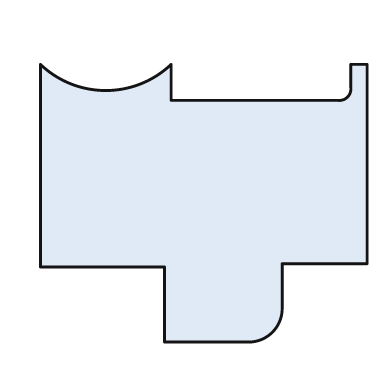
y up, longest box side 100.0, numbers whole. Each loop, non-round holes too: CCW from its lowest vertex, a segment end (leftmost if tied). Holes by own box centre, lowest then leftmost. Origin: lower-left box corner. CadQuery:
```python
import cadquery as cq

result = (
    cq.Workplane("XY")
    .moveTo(38.0, 0.0)
    .lineTo(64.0, 0.0)
    .threePointArc((71.0, 3.0), (74.0, 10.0))
    .lineTo(74.0, 24.0)
    .lineTo(100.0, 24.0)
    .lineTo(100.0, 85.0)
    .lineTo(95.0, 85.0)
    .lineTo(95.0, 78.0)
    .threePointArc((94.0, 75.0), (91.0, 74.0))
    .lineTo(40.0, 74.0)
    .lineTo(40.0, 85.0)
    .threePointArc((20.0, 77.0), (0.0, 85.0))
    .lineTo(0.0, 23.0)
    .lineTo(38.0, 23.0)
    .close()
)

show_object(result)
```